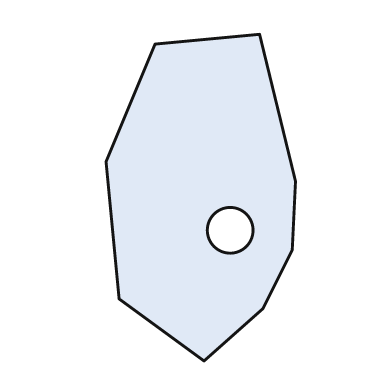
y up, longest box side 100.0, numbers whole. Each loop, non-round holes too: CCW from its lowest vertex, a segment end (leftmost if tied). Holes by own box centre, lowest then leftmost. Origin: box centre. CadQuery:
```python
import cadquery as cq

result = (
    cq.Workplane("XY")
    .moveTo(1.0, -50.0)
    .lineTo(19.0, -34.0)
    .lineTo(28.0, -16.0)
    .lineTo(29.0, 5.0)
    .lineTo(18.0, 50.0)
    .lineTo(-14.0, 47.0)
    .lineTo(-29.0, 11.0)
    .lineTo(-25.0, -31.0)
    .close()
    .moveTo(9.0, -10.0)
    .circle(7.0)
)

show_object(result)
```